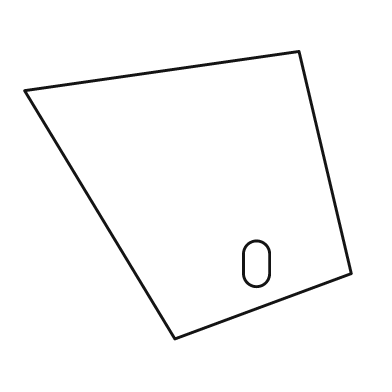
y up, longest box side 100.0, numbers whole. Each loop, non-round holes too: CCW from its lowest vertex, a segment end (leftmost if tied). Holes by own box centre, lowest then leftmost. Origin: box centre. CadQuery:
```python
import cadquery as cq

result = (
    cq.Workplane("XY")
    .moveTo(-4.0, -44.0)
    .lineTo(50.0, -24.0)
    .lineTo(34.0, 44.0)
    .lineTo(-50.0, 32.0)
    .close()
    .moveTo(17.0, -24.0)
    .threePointArc((21.0, -28.0), (25.0, -24.0))
    .lineTo(25.0, -18.0)
    .threePointArc((21.0, -14.0), (17.0, -18.0))
    .close()
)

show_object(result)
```